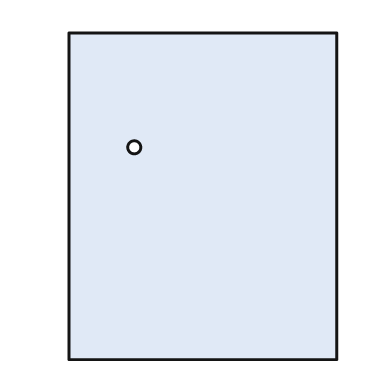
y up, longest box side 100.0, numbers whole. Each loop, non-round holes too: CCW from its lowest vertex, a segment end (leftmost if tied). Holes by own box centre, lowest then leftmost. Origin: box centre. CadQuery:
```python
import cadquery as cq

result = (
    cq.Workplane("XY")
    .moveTo(-41.0, -50.0)
    .lineTo(41.0, -50.0)
    .lineTo(41.0, 50.0)
    .lineTo(-41.0, 50.0)
    .close()
    .moveTo(-21.0, 15.0)
    .circle(2.0)
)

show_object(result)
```